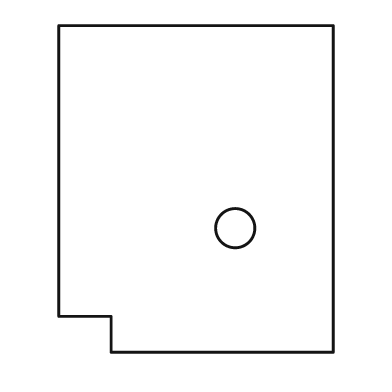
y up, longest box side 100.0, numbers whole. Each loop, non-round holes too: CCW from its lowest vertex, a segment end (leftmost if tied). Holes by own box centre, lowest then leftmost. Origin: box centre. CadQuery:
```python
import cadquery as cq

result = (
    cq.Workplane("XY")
    .moveTo(-26.0, -50.0)
    .lineTo(42.0, -50.0)
    .lineTo(42.0, 50.0)
    .lineTo(-42.0, 50.0)
    .lineTo(-42.0, -39.0)
    .lineTo(-26.0, -39.0)
    .close()
    .moveTo(12.0, -12.0)
    .circle(6.0)
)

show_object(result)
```